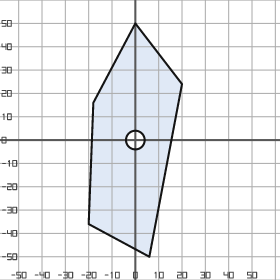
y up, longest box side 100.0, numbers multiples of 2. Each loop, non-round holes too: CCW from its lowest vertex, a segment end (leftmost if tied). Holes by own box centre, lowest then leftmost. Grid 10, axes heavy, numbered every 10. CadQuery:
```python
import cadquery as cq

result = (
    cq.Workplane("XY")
    .moveTo(6.0, -50.0)
    .lineTo(20.0, 24.0)
    .lineTo(0.0, 50.0)
    .lineTo(-18.0, 16.0)
    .lineTo(-20.0, -36.0)
    .close()
    .moveTo(0.0, 0.0)
    .circle(4.0)
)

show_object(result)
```